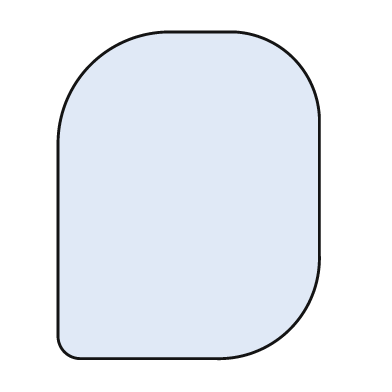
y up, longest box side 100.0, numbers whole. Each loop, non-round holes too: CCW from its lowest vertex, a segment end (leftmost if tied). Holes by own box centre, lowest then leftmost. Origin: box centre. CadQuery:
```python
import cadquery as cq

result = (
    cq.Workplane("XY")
    .moveTo(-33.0, -50.0)
    .lineTo(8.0, -50.0)
    .threePointArc((31.0, -41.0), (40.0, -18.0))
    .lineTo(40.0, 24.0)
    .threePointArc((32.0, 42.0), (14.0, 50.0))
    .lineTo(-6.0, 50.0)
    .threePointArc((-30.0, 40.0), (-40.0, 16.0))
    .lineTo(-40.0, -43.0)
    .threePointArc((-38.0, -48.0), (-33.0, -50.0))
    .close()
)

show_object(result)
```